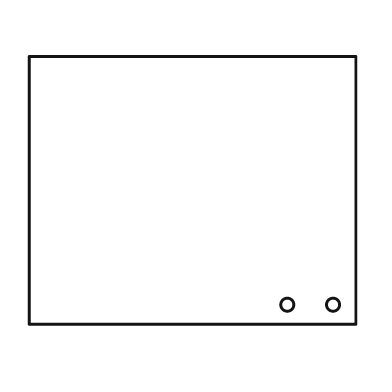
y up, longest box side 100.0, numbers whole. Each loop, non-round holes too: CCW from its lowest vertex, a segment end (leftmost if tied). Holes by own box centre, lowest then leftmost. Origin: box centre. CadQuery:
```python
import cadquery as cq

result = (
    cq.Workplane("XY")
    .moveTo(-50.0, -41.0)
    .lineTo(50.0, -41.0)
    .lineTo(50.0, 41.0)
    .lineTo(-50.0, 41.0)
    .close()
    .moveTo(29.0, -35.0)
    .circle(2.0)
    .moveTo(43.0, -35.0)
    .circle(2.0)
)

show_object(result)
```